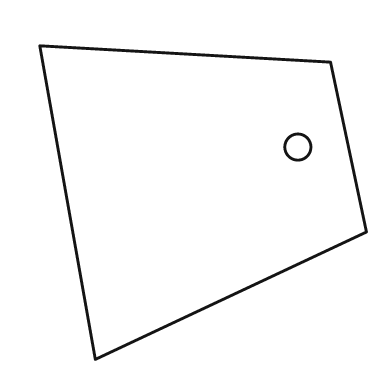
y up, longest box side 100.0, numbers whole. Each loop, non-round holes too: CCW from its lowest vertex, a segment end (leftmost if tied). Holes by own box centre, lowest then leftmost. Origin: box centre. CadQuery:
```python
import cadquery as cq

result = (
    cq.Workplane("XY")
    .moveTo(-33.0, -48.0)
    .lineTo(50.0, -9.0)
    .lineTo(39.0, 43.0)
    .lineTo(-50.0, 48.0)
    .close()
    .moveTo(29.0, 17.0)
    .circle(4.0)
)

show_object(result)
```